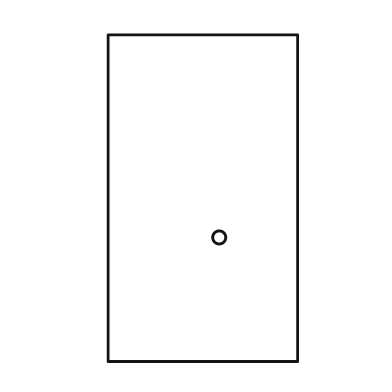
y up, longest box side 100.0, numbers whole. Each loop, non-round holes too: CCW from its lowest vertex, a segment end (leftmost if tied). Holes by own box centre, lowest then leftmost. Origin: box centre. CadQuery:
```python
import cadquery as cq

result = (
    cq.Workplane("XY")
    .moveTo(-29.0, -50.0)
    .lineTo(29.0, -50.0)
    .lineTo(29.0, 50.0)
    .lineTo(-29.0, 50.0)
    .close()
    .moveTo(5.0, -12.0)
    .circle(2.0)
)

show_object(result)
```